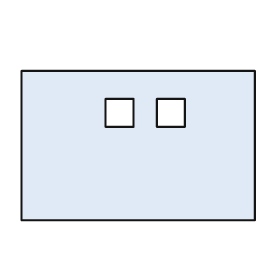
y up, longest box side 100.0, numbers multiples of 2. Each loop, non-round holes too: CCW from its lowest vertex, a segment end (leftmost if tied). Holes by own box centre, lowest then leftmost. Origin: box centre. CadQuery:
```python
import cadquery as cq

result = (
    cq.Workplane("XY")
    .moveTo(-50.0, -32.0)
    .lineTo(50.0, -32.0)
    .lineTo(50.0, 32.0)
    .lineTo(-50.0, 32.0)
    .close()
    .moveTo(-14.0, 8.0)
    .lineTo(-2.0, 8.0)
    .lineTo(-2.0, 20.0)
    .lineTo(-14.0, 20.0)
    .close()
    .moveTo(8.0, 8.0)
    .lineTo(20.0, 8.0)
    .lineTo(20.0, 20.0)
    .lineTo(8.0, 20.0)
    .close()
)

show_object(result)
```